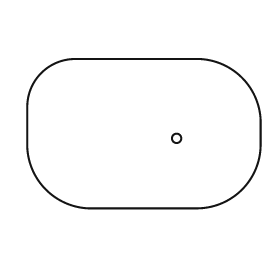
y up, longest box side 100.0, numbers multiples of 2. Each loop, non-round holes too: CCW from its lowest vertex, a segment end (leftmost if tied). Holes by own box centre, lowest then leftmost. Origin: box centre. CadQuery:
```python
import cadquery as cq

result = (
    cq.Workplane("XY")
    .moveTo(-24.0, -32.0)
    .lineTo(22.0, -32.0)
    .threePointArc((42.0, -24.0), (50.0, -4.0))
    .lineTo(50.0, 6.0)
    .threePointArc((42.0, 24.0), (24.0, 32.0))
    .lineTo(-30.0, 32.0)
    .threePointArc((-44.0, 26.0), (-50.0, 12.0))
    .lineTo(-50.0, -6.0)
    .threePointArc((-42.0, -24.0), (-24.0, -32.0))
    .close()
    .moveTo(14.0, -2.0)
    .circle(2.0)
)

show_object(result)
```